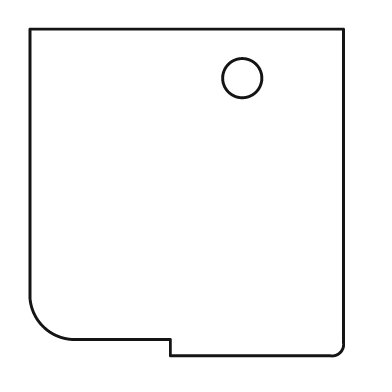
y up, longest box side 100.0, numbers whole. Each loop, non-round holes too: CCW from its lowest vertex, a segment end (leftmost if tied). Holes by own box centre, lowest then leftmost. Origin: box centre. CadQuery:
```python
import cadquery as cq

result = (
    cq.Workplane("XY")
    .moveTo(-5.0, -50.0)
    .lineTo(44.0, -50.0)
    .threePointArc((47.0, -49.0), (48.0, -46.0))
    .lineTo(48.0, 50.0)
    .lineTo(-48.0, 50.0)
    .lineTo(-48.0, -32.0)
    .threePointArc((-44.0, -41.0), (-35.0, -45.0))
    .lineTo(-5.0, -45.0)
    .close()
    .moveTo(17.0, 35.0)
    .circle(6.0)
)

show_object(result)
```